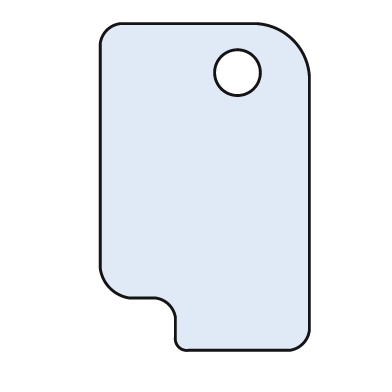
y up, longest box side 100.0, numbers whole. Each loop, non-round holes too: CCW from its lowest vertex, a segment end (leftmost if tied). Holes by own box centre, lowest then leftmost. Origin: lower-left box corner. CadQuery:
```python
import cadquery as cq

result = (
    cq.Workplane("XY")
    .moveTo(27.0, 0.0)
    .lineTo(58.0, 0.0)
    .threePointArc((62.0, 2.0), (64.0, 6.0))
    .lineTo(64.0, 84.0)
    .threePointArc((59.0, 95.0), (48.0, 100.0))
    .lineTo(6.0, 100.0)
    .threePointArc((2.0, 98.0), (0.0, 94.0))
    .lineTo(0.0, 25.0)
    .threePointArc((3.0, 19.0), (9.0, 16.0))
    .lineTo(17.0, 16.0)
    .threePointArc((21.0, 14.0), (23.0, 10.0))
    .lineTo(23.0, 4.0)
    .threePointArc((24.0, 1.0), (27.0, 0.0))
    .close()
    .moveTo(42.0, 85.0)
    .circle(7.0)
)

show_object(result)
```